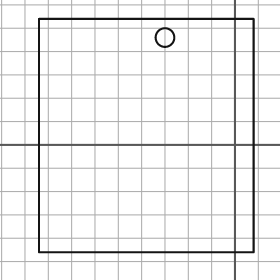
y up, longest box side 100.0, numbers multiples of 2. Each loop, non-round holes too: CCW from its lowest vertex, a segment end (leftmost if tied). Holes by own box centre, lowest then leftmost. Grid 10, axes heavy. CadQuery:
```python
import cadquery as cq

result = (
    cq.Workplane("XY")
    .moveTo(-84.0, -46.0)
    .lineTo(8.0, -46.0)
    .lineTo(8.0, 54.0)
    .lineTo(-84.0, 54.0)
    .close()
    .moveTo(-30.0, 46.0)
    .circle(4.0)
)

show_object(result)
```